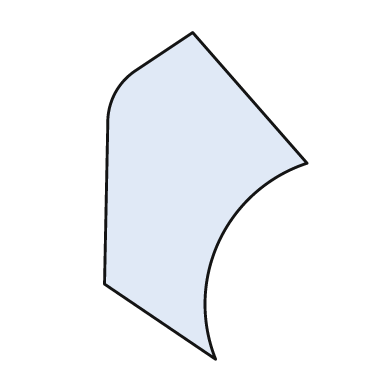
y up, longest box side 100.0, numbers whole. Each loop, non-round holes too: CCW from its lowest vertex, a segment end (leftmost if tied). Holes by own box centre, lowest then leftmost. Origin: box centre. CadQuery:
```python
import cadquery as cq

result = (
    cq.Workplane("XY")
    .moveTo(3.0, -50.0)
    .threePointArc((4.0, -14.0), (31.0, 10.0))
    .lineTo(-4.0, 50.0)
    .lineTo(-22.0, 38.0)
    .threePointArc((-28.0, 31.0), (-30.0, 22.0))
    .lineTo(-31.0, -27.0)
    .close()
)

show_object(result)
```